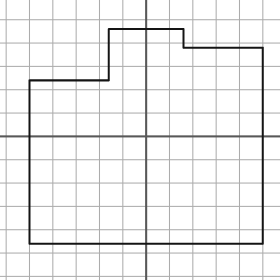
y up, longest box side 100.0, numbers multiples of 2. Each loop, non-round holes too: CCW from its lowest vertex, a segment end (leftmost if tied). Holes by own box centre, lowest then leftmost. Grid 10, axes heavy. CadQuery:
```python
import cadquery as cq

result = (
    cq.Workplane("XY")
    .moveTo(-50.0, -46.0)
    .lineTo(50.0, -46.0)
    .lineTo(50.0, 38.0)
    .lineTo(16.0, 38.0)
    .lineTo(16.0, 46.0)
    .lineTo(-16.0, 46.0)
    .lineTo(-16.0, 24.0)
    .lineTo(-50.0, 24.0)
    .close()
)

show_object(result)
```